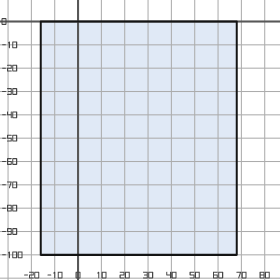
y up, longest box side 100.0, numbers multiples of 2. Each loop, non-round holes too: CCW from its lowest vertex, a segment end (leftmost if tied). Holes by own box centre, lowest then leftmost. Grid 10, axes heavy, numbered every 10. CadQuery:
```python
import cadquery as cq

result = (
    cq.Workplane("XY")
    .moveTo(-16.0, -100.0)
    .lineTo(68.0, -100.0)
    .lineTo(68.0, 0.0)
    .lineTo(-16.0, 0.0)
    .close()
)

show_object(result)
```